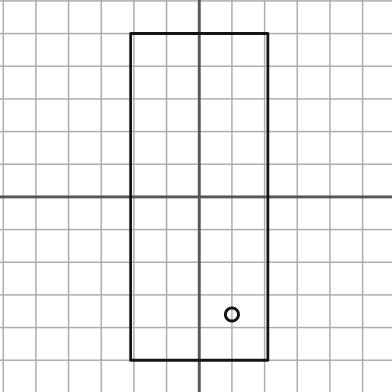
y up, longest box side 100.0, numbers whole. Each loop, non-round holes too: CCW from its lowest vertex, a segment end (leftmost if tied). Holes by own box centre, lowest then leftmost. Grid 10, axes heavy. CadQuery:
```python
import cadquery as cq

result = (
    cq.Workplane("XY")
    .moveTo(-21.0, -50.0)
    .lineTo(21.0, -50.0)
    .lineTo(21.0, 50.0)
    .lineTo(-21.0, 50.0)
    .close()
    .moveTo(10.0, -36.0)
    .circle(2.0)
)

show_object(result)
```